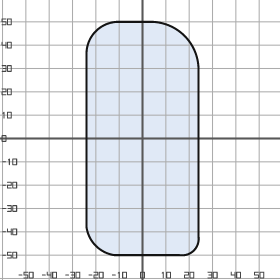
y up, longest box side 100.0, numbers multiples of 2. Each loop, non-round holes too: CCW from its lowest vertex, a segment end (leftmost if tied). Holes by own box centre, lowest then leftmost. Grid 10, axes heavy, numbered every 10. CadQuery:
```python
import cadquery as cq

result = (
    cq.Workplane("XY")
    .moveTo(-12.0, -50.0)
    .lineTo(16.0, -50.0)
    .threePointArc((22.0, -48.0), (24.0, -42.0))
    .lineTo(24.0, 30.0)
    .threePointArc((18.0, 44.0), (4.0, 50.0))
    .lineTo(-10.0, 50.0)
    .threePointArc((-20.0, 46.0), (-24.0, 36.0))
    .lineTo(-24.0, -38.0)
    .threePointArc((-20.0, -46.0), (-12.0, -50.0))
    .close()
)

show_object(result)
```